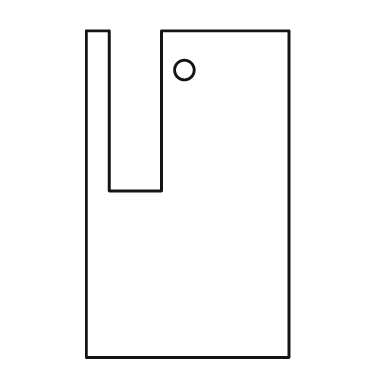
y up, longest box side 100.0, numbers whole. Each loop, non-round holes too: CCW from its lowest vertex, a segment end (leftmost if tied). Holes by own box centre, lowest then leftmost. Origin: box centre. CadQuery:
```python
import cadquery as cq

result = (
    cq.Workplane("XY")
    .moveTo(-31.0, -50.0)
    .lineTo(31.0, -50.0)
    .lineTo(31.0, 50.0)
    .lineTo(-8.0, 50.0)
    .lineTo(-8.0, 1.0)
    .lineTo(-24.0, 1.0)
    .lineTo(-24.0, 50.0)
    .lineTo(-31.0, 50.0)
    .close()
    .moveTo(-1.0, 38.0)
    .circle(3.0)
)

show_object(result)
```